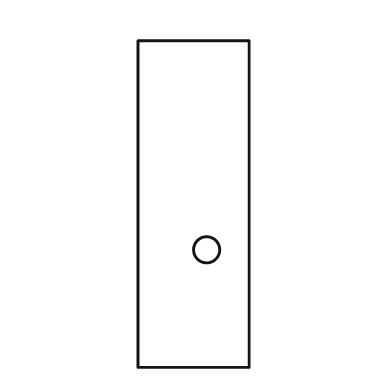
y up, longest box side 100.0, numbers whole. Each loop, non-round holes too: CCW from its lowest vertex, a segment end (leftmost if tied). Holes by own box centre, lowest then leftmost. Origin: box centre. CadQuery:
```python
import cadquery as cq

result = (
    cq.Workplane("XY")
    .moveTo(-17.0, -50.0)
    .lineTo(17.0, -50.0)
    .lineTo(17.0, 50.0)
    .lineTo(-17.0, 50.0)
    .close()
    .moveTo(4.0, -14.0)
    .circle(4.0)
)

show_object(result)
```